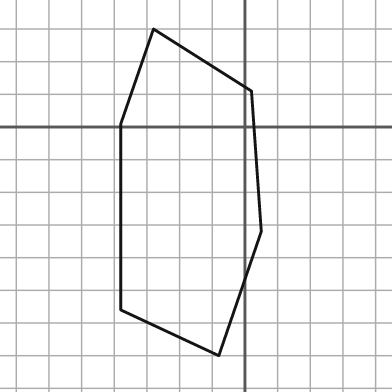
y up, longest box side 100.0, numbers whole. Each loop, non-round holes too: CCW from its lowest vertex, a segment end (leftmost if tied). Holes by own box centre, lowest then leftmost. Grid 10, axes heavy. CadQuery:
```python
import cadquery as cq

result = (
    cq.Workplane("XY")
    .moveTo(-8.0, -70.0)
    .lineTo(5.0, -32.0)
    .lineTo(2.0, 11.0)
    .lineTo(-28.0, 30.0)
    .lineTo(-38.0, 1.0)
    .lineTo(-38.0, -56.0)
    .close()
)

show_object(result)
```